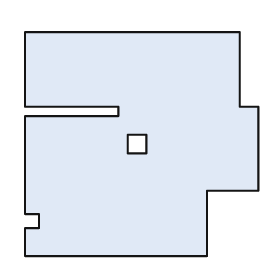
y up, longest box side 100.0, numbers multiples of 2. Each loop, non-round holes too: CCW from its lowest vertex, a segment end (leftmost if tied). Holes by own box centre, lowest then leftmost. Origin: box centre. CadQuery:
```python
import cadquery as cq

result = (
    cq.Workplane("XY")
    .moveTo(-50.0, -48.0)
    .lineTo(28.0, -48.0)
    .lineTo(28.0, -20.0)
    .lineTo(50.0, -20.0)
    .lineTo(50.0, 16.0)
    .lineTo(42.0, 16.0)
    .lineTo(42.0, 48.0)
    .lineTo(-50.0, 48.0)
    .lineTo(-50.0, 16.0)
    .lineTo(-10.0, 16.0)
    .lineTo(-10.0, 12.0)
    .lineTo(-50.0, 12.0)
    .lineTo(-50.0, -30.0)
    .lineTo(-44.0, -30.0)
    .lineTo(-44.0, -36.0)
    .lineTo(-50.0, -36.0)
    .close()
    .moveTo(-6.0, -4.0)
    .lineTo(2.0, -4.0)
    .lineTo(2.0, 4.0)
    .lineTo(-6.0, 4.0)
    .close()
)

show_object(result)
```